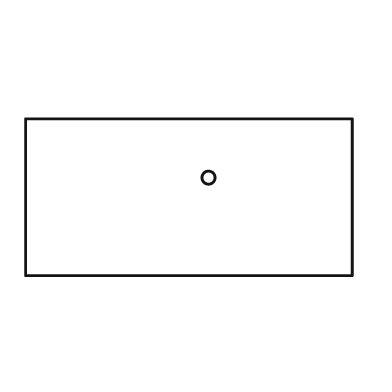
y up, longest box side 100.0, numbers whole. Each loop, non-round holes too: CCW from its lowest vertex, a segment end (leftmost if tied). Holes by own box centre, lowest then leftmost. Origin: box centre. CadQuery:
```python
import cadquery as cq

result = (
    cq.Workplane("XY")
    .moveTo(-50.0, -24.0)
    .lineTo(50.0, -24.0)
    .lineTo(50.0, 24.0)
    .lineTo(-50.0, 24.0)
    .close()
    .moveTo(6.0, 6.0)
    .circle(2.0)
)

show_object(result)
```